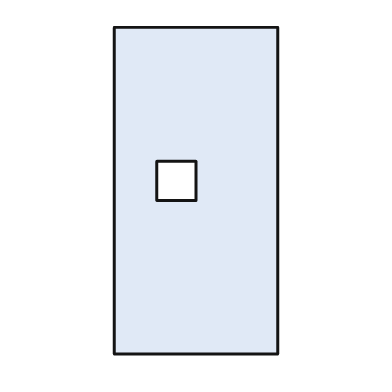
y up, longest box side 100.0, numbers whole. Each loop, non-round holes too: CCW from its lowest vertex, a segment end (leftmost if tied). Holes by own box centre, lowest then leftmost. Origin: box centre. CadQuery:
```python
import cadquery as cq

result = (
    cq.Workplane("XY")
    .moveTo(-25.0, -50.0)
    .lineTo(25.0, -50.0)
    .lineTo(25.0, 50.0)
    .lineTo(-25.0, 50.0)
    .close()
    .moveTo(-12.0, -3.0)
    .lineTo(0.0, -3.0)
    .lineTo(0.0, 9.0)
    .lineTo(-12.0, 9.0)
    .close()
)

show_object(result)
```